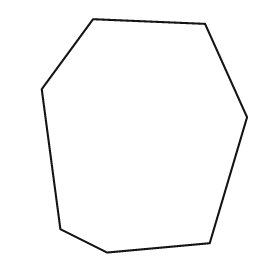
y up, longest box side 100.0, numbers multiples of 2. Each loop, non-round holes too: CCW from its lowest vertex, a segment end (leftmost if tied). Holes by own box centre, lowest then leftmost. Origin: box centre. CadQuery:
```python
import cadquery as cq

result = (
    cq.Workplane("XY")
    .moveTo(-16.0, -50.0)
    .lineTo(28.0, -46.0)
    .lineTo(44.0, 8.0)
    .lineTo(26.0, 48.0)
    .lineTo(-22.0, 50.0)
    .lineTo(-44.0, 20.0)
    .lineTo(-36.0, -40.0)
    .close()
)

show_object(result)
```